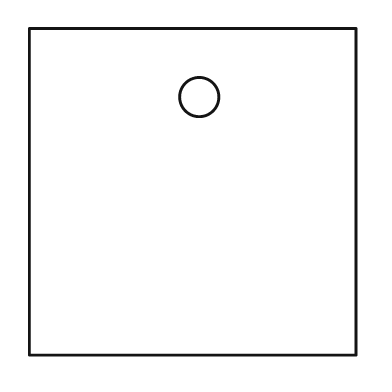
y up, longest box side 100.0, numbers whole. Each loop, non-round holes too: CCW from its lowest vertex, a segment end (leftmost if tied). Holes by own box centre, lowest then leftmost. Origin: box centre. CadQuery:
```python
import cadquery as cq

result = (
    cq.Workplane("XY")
    .moveTo(-50.0, -50.0)
    .lineTo(50.0, -50.0)
    .lineTo(50.0, 50.0)
    .lineTo(-50.0, 50.0)
    .close()
    .moveTo(2.0, 29.0)
    .circle(6.0)
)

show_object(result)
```